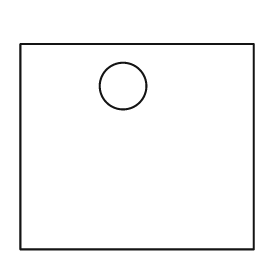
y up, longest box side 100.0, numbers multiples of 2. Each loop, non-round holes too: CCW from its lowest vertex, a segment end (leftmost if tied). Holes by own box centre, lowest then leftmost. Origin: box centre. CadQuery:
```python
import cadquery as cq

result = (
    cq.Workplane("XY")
    .moveTo(-50.0, -44.0)
    .lineTo(50.0, -44.0)
    .lineTo(50.0, 44.0)
    .lineTo(-50.0, 44.0)
    .close()
    .moveTo(-6.0, 26.0)
    .circle(10.0)
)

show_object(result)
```